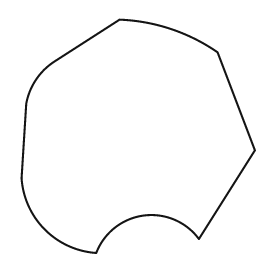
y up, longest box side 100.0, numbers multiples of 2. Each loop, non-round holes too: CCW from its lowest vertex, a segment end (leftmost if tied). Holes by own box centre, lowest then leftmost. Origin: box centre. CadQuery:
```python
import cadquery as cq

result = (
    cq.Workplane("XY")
    .moveTo(-18.0, -50.0)
    .threePointArc((2.0, -34.0), (26.0, -44.0))
    .lineTo(50.0, -6.0)
    .lineTo(34.0, 36.0)
    .threePointArc((14.0, 46.0), (-8.0, 50.0))
    .lineTo(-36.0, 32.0)
    .threePointArc((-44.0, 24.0), (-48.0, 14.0))
    .lineTo(-50.0, -18.0)
    .threePointArc((-40.0, -40.0), (-18.0, -50.0))
    .close()
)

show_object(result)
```